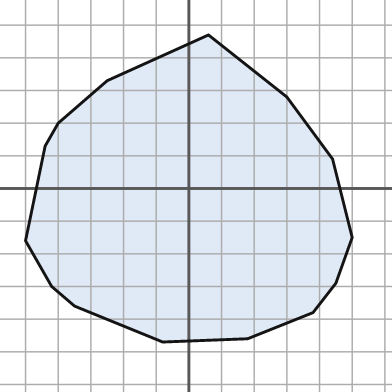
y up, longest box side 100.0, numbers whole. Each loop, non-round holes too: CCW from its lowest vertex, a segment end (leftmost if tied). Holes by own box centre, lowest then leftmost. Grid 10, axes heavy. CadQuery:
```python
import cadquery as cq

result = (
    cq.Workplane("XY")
    .moveTo(-8.0, -47.0)
    .lineTo(18.0, -46.0)
    .lineTo(38.0, -38.0)
    .lineTo(45.0, -29.0)
    .lineTo(50.0, -15.0)
    .lineTo(44.0, 9.0)
    .lineTo(30.0, 28.0)
    .lineTo(6.0, 47.0)
    .lineTo(-25.0, 33.0)
    .lineTo(-40.0, 20.0)
    .lineTo(-44.0, 13.0)
    .lineTo(-50.0, -16.0)
    .lineTo(-42.0, -30.0)
    .lineTo(-35.0, -36.0)
    .close()
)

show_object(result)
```